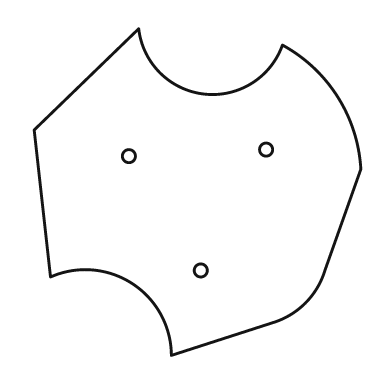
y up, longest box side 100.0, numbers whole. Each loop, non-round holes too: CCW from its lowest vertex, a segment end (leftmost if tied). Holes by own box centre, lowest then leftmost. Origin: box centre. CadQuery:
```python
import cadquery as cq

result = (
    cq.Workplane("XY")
    .moveTo(-8.0, -50.0)
    .lineTo(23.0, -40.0)
    .threePointArc((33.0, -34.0), (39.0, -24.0))
    .lineTo(50.0, 7.0)
    .threePointArc((43.0, 29.0), (26.0, 45.0))
    .threePointArc((2.0, 30.0), (-18.0, 50.0))
    .lineTo(-50.0, 19.0)
    .lineTo(-45.0, -26.0)
    .threePointArc((-20.0, -28.0), (-8.0, -50.0))
    .close()
    .moveTo(1.0, -24.0)
    .circle(2.0)
    .moveTo(-21.0, 11.0)
    .circle(2.0)
    .moveTo(21.0, 13.0)
    .circle(2.0)
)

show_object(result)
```